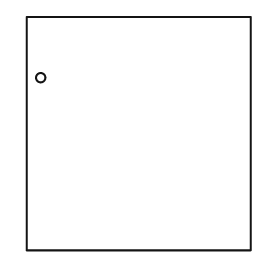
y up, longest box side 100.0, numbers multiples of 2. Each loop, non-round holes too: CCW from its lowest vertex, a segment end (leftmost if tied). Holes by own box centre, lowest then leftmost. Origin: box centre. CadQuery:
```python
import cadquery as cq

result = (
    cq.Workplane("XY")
    .moveTo(-48.0, -50.0)
    .lineTo(48.0, -50.0)
    .lineTo(48.0, 50.0)
    .lineTo(-48.0, 50.0)
    .close()
    .moveTo(-42.0, 24.0)
    .circle(2.0)
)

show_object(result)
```